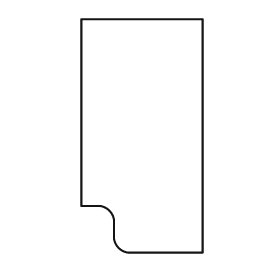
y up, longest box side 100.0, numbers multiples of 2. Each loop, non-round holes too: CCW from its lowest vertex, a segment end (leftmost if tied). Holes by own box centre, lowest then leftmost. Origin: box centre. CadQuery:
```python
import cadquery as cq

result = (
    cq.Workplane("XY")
    .moveTo(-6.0, -50.0)
    .lineTo(26.0, -50.0)
    .lineTo(26.0, 50.0)
    .lineTo(-26.0, 50.0)
    .lineTo(-26.0, -30.0)
    .lineTo(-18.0, -30.0)
    .threePointArc((-14.0, -32.0), (-12.0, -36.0))
    .lineTo(-12.0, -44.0)
    .threePointArc((-10.0, -48.0), (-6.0, -50.0))
    .close()
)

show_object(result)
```